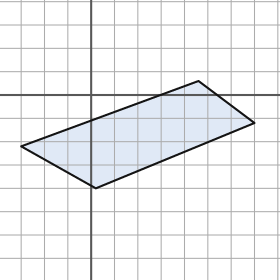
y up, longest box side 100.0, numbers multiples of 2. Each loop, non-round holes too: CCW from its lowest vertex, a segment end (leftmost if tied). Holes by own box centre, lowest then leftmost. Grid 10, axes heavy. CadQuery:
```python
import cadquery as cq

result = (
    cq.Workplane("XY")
    .moveTo(2.0, -40.0)
    .lineTo(70.0, -12.0)
    .lineTo(46.0, 6.0)
    .lineTo(-30.0, -22.0)
    .close()
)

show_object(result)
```